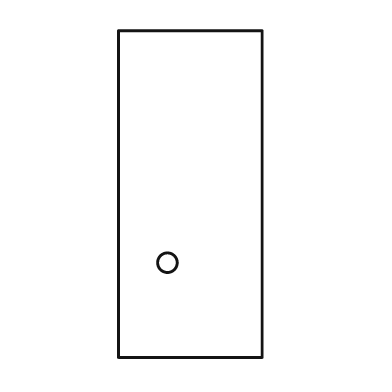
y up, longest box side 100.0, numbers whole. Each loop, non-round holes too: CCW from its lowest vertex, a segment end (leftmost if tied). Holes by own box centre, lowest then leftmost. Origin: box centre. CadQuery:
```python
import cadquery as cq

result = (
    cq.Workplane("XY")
    .moveTo(-22.0, -50.0)
    .lineTo(22.0, -50.0)
    .lineTo(22.0, 50.0)
    .lineTo(-22.0, 50.0)
    .close()
    .moveTo(-7.0, -21.0)
    .circle(3.0)
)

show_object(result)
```